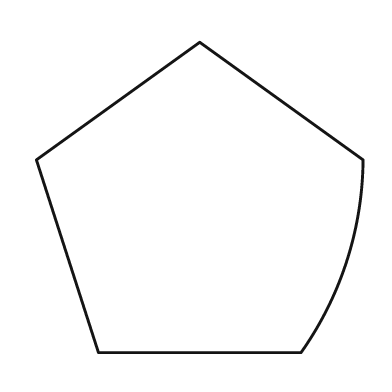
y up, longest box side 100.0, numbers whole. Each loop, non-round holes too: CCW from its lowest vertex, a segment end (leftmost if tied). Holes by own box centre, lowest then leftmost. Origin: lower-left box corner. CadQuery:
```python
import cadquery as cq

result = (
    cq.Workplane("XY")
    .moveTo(19.0, 0.0)
    .lineTo(81.0, 0.0)
    .threePointArc((95.0, 28.0), (100.0, 59.0))
    .lineTo(50.0, 95.0)
    .lineTo(0.0, 59.0)
    .close()
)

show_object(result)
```